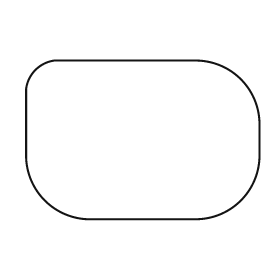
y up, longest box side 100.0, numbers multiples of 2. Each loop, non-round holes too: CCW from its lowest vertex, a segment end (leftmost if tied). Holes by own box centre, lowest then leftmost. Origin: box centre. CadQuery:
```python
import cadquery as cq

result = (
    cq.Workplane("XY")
    .moveTo(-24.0, -34.0)
    .lineTo(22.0, -34.0)
    .threePointArc((42.0, -26.0), (50.0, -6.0))
    .lineTo(50.0, 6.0)
    .threePointArc((42.0, 26.0), (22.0, 34.0))
    .lineTo(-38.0, 34.0)
    .threePointArc((-46.0, 30.0), (-50.0, 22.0))
    .lineTo(-50.0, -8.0)
    .threePointArc((-42.0, -26.0), (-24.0, -34.0))
    .close()
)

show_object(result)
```